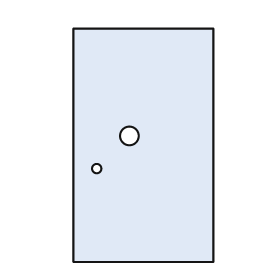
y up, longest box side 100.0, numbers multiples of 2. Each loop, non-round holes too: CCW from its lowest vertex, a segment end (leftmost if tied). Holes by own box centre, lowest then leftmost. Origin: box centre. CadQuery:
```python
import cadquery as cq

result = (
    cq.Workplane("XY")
    .moveTo(-30.0, -50.0)
    .lineTo(30.0, -50.0)
    .lineTo(30.0, 50.0)
    .lineTo(-30.0, 50.0)
    .close()
    .moveTo(-20.0, -10.0)
    .circle(2.0)
    .moveTo(-6.0, 4.0)
    .circle(4.0)
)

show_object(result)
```